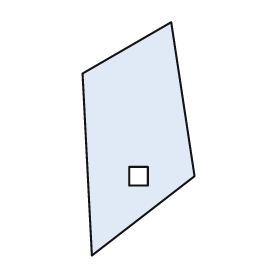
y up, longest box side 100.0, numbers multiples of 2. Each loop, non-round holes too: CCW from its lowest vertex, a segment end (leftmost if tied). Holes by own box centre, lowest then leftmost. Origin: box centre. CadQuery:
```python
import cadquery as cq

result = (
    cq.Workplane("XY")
    .moveTo(-20.0, -50.0)
    .lineTo(24.0, -16.0)
    .lineTo(14.0, 50.0)
    .lineTo(-24.0, 28.0)
    .close()
    .moveTo(-4.0, -20.0)
    .lineTo(4.0, -20.0)
    .lineTo(4.0, -12.0)
    .lineTo(-4.0, -12.0)
    .close()
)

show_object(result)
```